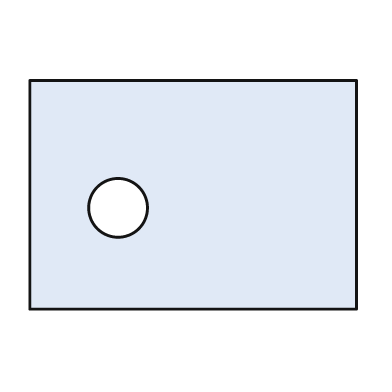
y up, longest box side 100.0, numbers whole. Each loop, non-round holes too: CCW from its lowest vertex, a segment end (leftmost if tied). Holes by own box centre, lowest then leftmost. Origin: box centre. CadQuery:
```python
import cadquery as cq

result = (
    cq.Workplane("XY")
    .moveTo(-50.0, -35.0)
    .lineTo(50.0, -35.0)
    .lineTo(50.0, 35.0)
    .lineTo(-50.0, 35.0)
    .close()
    .moveTo(-23.0, -4.0)
    .circle(9.0)
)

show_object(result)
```